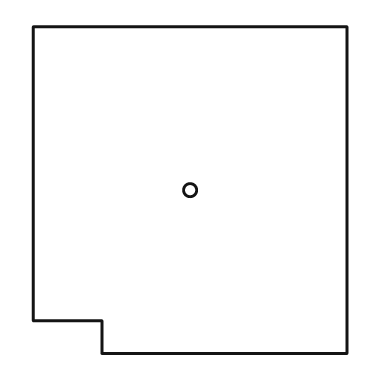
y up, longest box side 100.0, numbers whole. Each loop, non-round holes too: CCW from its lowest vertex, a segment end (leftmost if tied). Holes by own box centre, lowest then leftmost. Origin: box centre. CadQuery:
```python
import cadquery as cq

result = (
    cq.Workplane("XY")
    .moveTo(-27.0, -50.0)
    .lineTo(48.0, -50.0)
    .lineTo(48.0, 50.0)
    .lineTo(-48.0, 50.0)
    .lineTo(-48.0, -40.0)
    .lineTo(-27.0, -40.0)
    .close()
    .moveTo(0.0, 0.0)
    .circle(2.0)
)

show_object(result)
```